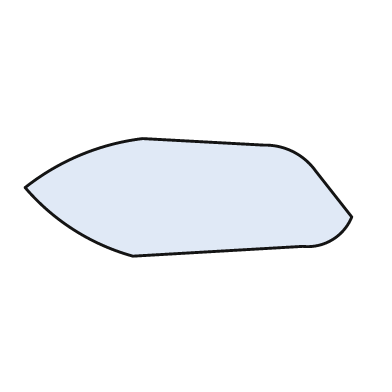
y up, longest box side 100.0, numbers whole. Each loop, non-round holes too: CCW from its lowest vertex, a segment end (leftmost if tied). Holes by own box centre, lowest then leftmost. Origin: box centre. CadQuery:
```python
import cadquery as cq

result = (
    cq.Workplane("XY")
    .moveTo(-17.0, -18.0)
    .lineTo(35.0, -15.0)
    .threePointArc((44.0, -13.0), (50.0, -6.0))
    .lineTo(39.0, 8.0)
    .threePointArc((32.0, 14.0), (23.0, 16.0))
    .lineTo(-14.0, 18.0)
    .threePointArc((-33.0, 13.0), (-50.0, 3.0))
    .threePointArc((-35.0, -10.0), (-17.0, -18.0))
    .close()
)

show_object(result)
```